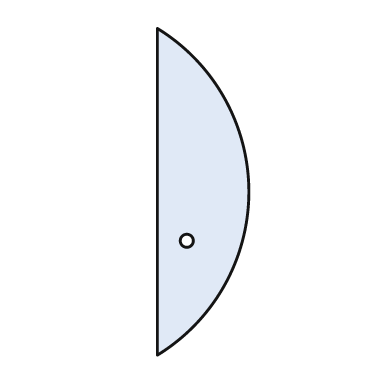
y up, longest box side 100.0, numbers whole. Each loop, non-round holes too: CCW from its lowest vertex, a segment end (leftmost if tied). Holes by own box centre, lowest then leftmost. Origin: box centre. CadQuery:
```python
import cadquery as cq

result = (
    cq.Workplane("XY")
    .moveTo(-14.0, -50.0)
    .threePointArc((14.0, 0.0), (-14.0, 50.0))
    .close()
    .moveTo(-5.0, -15.0)
    .circle(2.0)
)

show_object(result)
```